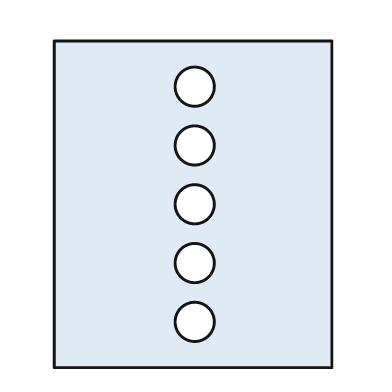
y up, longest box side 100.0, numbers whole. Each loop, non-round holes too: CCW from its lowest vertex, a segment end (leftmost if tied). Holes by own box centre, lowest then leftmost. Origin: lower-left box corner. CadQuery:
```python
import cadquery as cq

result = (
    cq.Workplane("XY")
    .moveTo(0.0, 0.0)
    .lineTo(85.0, 0.0)
    .lineTo(85.0, 100.0)
    .lineTo(0.0, 100.0)
    .close()
    .moveTo(43.0, 14.0)
    .circle(6.0)
    .moveTo(43.0, 32.0)
    .circle(6.0)
    .moveTo(43.0, 50.0)
    .circle(6.0)
    .moveTo(43.0, 68.0)
    .circle(6.0)
    .moveTo(43.0, 86.0)
    .circle(6.0)
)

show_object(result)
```